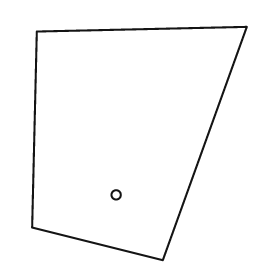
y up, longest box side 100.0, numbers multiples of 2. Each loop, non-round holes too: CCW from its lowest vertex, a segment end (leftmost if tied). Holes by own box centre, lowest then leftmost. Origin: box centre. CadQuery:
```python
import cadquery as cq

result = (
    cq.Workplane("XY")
    .moveTo(10.0, -50.0)
    .lineTo(46.0, 50.0)
    .lineTo(-44.0, 48.0)
    .lineTo(-46.0, -36.0)
    .close()
    .moveTo(-10.0, -22.0)
    .circle(2.0)
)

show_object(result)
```